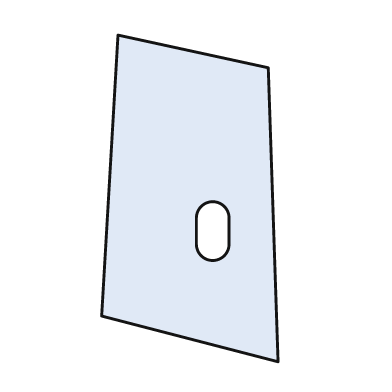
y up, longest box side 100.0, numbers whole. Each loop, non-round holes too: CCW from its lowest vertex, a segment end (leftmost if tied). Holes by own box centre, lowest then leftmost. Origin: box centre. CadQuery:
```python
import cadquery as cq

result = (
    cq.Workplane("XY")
    .moveTo(27.0, -50.0)
    .lineTo(24.0, 40.0)
    .lineTo(-22.0, 50.0)
    .lineTo(-27.0, -36.0)
    .close()
    .moveTo(2.0, -14.0)
    .threePointArc((7.0, -19.0), (12.0, -14.0))
    .lineTo(12.0, -6.0)
    .threePointArc((7.0, -1.0), (2.0, -6.0))
    .close()
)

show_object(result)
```